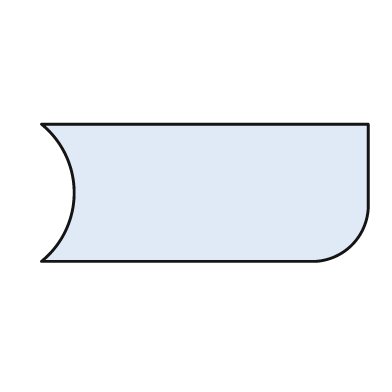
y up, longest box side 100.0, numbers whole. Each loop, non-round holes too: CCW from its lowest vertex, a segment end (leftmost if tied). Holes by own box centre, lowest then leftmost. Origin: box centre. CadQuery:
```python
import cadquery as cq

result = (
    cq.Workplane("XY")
    .moveTo(-50.0, -21.0)
    .lineTo(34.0, -21.0)
    .threePointArc((45.0, -16.0), (50.0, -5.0))
    .lineTo(50.0, 21.0)
    .lineTo(-50.0, 21.0)
    .threePointArc((-40.0, 0.0), (-50.0, -21.0))
    .close()
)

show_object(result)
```